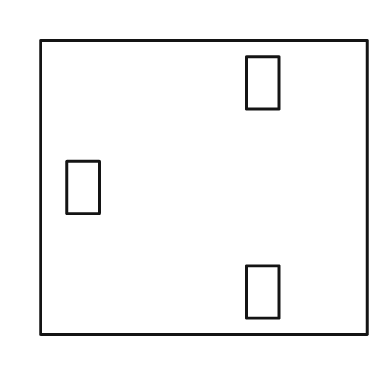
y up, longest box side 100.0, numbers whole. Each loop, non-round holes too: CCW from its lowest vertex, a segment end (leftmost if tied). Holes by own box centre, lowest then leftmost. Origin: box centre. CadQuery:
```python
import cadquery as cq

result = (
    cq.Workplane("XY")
    .moveTo(-50.0, -45.0)
    .lineTo(50.0, -45.0)
    .lineTo(50.0, 45.0)
    .lineTo(-50.0, 45.0)
    .close()
    .moveTo(13.0, -40.0)
    .lineTo(23.0, -40.0)
    .lineTo(23.0, -24.0)
    .lineTo(13.0, -24.0)
    .close()
    .moveTo(-42.0, -8.0)
    .lineTo(-32.0, -8.0)
    .lineTo(-32.0, 8.0)
    .lineTo(-42.0, 8.0)
    .close()
    .moveTo(13.0, 24.0)
    .lineTo(23.0, 24.0)
    .lineTo(23.0, 40.0)
    .lineTo(13.0, 40.0)
    .close()
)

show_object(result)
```